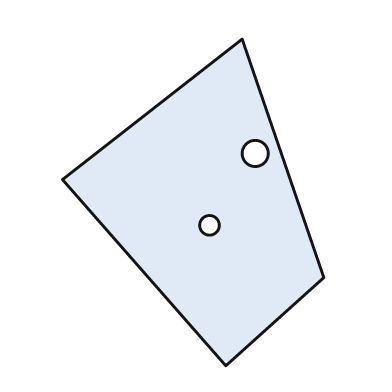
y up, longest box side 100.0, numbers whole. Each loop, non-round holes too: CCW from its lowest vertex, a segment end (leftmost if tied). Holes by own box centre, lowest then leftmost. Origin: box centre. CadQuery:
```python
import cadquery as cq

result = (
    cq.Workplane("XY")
    .moveTo(10.0, -50.0)
    .lineTo(40.0, -23.0)
    .lineTo(15.0, 50.0)
    .lineTo(-40.0, 7.0)
    .close()
    .moveTo(5.0, -7.0)
    .circle(3.0)
    .moveTo(19.0, 15.0)
    .circle(4.0)
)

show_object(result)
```